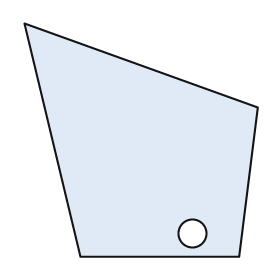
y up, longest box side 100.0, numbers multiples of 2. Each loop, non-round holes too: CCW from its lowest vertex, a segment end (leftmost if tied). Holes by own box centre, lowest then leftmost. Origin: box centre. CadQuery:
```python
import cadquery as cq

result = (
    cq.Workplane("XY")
    .moveTo(-26.0, -50.0)
    .lineTo(42.0, -50.0)
    .lineTo(50.0, 14.0)
    .lineTo(-50.0, 50.0)
    .close()
    .moveTo(22.0, -40.0)
    .circle(6.0)
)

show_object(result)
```